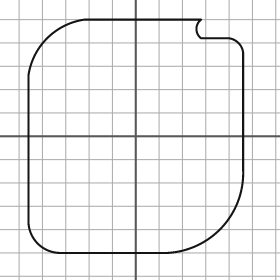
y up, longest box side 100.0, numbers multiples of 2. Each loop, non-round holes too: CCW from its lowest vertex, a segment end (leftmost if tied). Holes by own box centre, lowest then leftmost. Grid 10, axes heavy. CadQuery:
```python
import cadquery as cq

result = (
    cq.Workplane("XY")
    .moveTo(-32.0, -50.0)
    .lineTo(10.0, -50.0)
    .threePointArc((36.0, -40.0), (46.0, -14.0))
    .lineTo(46.0, 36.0)
    .threePointArc((44.0, 40.0), (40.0, 42.0))
    .lineTo(28.0, 42.0)
    .threePointArc((26.0, 46.0), (28.0, 50.0))
    .lineTo(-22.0, 50.0)
    .threePointArc((-38.0, 42.0), (-46.0, 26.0))
    .lineTo(-46.0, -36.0)
    .threePointArc((-42.0, -46.0), (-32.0, -50.0))
    .close()
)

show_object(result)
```